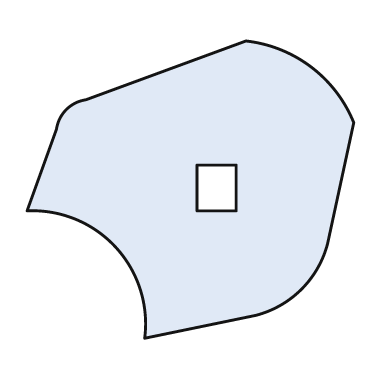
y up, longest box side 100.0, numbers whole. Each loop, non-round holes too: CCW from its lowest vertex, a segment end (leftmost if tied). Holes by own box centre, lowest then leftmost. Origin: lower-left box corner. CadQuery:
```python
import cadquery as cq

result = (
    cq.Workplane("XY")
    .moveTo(36.0, 0.0)
    .lineTo(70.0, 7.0)
    .threePointArc((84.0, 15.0), (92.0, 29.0))
    .lineTo(100.0, 66.0)
    .threePointArc((87.0, 83.0), (67.0, 91.0))
    .lineTo(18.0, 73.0)
    .threePointArc((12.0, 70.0), (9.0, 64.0))
    .lineTo(0.0, 39.0)
    .threePointArc((27.0, 28.0), (36.0, 0.0))
    .close()
    .moveTo(52.0, 39.0)
    .lineTo(64.0, 39.0)
    .lineTo(64.0, 53.0)
    .lineTo(52.0, 53.0)
    .close()
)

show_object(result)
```